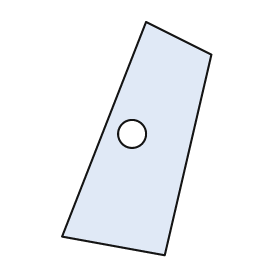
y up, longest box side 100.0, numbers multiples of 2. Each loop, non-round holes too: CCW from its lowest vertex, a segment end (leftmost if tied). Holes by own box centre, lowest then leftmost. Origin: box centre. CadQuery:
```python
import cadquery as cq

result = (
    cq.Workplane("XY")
    .moveTo(12.0, -50.0)
    .lineTo(32.0, 36.0)
    .lineTo(4.0, 50.0)
    .lineTo(-32.0, -42.0)
    .close()
    .moveTo(-2.0, 2.0)
    .circle(6.0)
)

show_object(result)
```